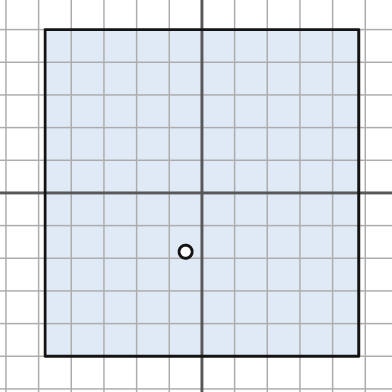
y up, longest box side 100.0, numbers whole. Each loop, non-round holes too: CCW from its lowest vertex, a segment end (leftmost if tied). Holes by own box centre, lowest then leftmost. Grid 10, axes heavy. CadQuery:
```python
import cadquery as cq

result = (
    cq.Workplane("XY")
    .moveTo(-48.0, -50.0)
    .lineTo(48.0, -50.0)
    .lineTo(48.0, 50.0)
    .lineTo(-48.0, 50.0)
    .close()
    .moveTo(-5.0, -18.0)
    .circle(2.0)
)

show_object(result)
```